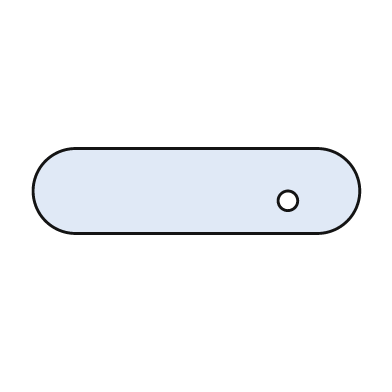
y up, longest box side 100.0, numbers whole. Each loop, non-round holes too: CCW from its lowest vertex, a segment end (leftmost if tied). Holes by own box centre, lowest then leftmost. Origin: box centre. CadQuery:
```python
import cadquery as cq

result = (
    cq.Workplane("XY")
    .moveTo(-37.0, -13.0)
    .lineTo(37.0, -13.0)
    .threePointArc((50.0, 0.0), (37.0, 13.0))
    .lineTo(-37.0, 13.0)
    .threePointArc((-50.0, 0.0), (-37.0, -13.0))
    .close()
    .moveTo(28.0, -3.0)
    .circle(3.0)
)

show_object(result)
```